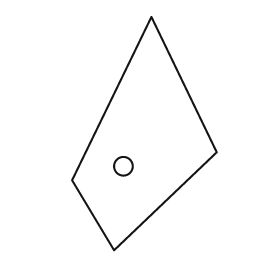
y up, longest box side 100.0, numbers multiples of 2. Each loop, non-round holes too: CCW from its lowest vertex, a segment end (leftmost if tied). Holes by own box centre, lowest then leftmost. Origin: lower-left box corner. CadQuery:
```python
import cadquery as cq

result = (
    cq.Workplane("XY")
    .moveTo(18.0, 0.0)
    .lineTo(62.0, 42.0)
    .lineTo(34.0, 100.0)
    .lineTo(0.0, 30.0)
    .close()
    .moveTo(22.0, 36.0)
    .circle(4.0)
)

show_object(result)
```